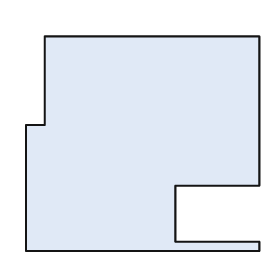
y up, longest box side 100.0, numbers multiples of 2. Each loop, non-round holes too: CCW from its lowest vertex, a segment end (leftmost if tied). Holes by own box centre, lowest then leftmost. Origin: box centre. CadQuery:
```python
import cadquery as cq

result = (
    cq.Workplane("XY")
    .moveTo(-50.0, -46.0)
    .lineTo(50.0, -46.0)
    .lineTo(50.0, -42.0)
    .lineTo(14.0, -42.0)
    .lineTo(14.0, -18.0)
    .lineTo(50.0, -18.0)
    .lineTo(50.0, 46.0)
    .lineTo(-42.0, 46.0)
    .lineTo(-42.0, 8.0)
    .lineTo(-50.0, 8.0)
    .close()
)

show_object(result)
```